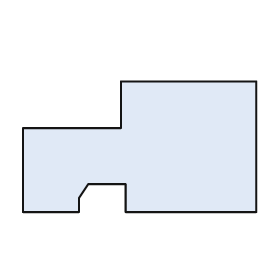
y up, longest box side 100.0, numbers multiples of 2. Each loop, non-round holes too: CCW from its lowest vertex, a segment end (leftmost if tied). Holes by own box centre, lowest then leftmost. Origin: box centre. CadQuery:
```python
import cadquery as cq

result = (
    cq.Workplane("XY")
    .moveTo(-50.0, -28.0)
    .lineTo(-26.0, -28.0)
    .lineTo(-26.0, -22.0)
    .lineTo(-22.0, -16.0)
    .lineTo(-6.0, -16.0)
    .lineTo(-6.0, -28.0)
    .lineTo(50.0, -28.0)
    .lineTo(50.0, 28.0)
    .lineTo(-8.0, 28.0)
    .lineTo(-8.0, 8.0)
    .lineTo(-50.0, 8.0)
    .close()
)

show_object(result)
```